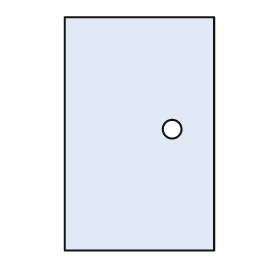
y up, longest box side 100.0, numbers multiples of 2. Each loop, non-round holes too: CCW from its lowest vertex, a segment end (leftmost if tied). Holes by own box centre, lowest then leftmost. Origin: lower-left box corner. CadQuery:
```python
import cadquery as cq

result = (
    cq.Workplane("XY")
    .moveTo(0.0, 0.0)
    .lineTo(64.0, 0.0)
    .lineTo(64.0, 100.0)
    .lineTo(0.0, 100.0)
    .close()
    .moveTo(46.0, 52.0)
    .circle(4.0)
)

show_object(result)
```